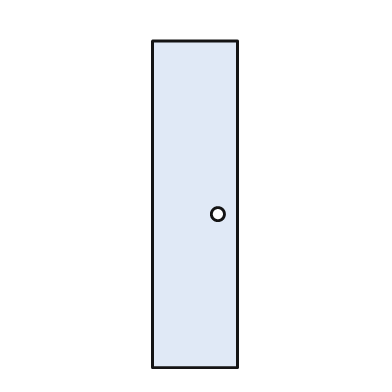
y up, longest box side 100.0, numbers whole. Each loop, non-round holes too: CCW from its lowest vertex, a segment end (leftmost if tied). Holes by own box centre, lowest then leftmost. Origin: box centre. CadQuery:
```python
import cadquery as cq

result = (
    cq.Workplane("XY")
    .moveTo(-13.0, -50.0)
    .lineTo(13.0, -50.0)
    .lineTo(13.0, 50.0)
    .lineTo(-13.0, 50.0)
    .close()
    .moveTo(7.0, -3.0)
    .circle(2.0)
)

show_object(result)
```